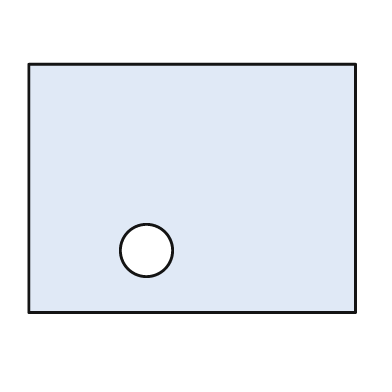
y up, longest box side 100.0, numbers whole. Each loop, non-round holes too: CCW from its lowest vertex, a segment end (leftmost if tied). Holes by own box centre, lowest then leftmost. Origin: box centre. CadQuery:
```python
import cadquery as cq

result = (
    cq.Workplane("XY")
    .moveTo(-50.0, -38.0)
    .lineTo(50.0, -38.0)
    .lineTo(50.0, 38.0)
    .lineTo(-50.0, 38.0)
    .close()
    .moveTo(-14.0, -19.0)
    .circle(8.0)
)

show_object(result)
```